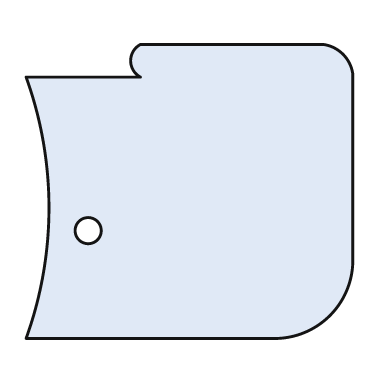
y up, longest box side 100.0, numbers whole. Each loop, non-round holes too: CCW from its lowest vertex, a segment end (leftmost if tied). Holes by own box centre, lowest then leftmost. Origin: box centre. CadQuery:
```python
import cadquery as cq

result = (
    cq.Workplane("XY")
    .moveTo(-50.0, -45.0)
    .lineTo(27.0, -45.0)
    .threePointArc((43.0, -38.0), (50.0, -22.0))
    .lineTo(50.0, 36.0)
    .threePointArc((47.0, 42.0), (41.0, 45.0))
    .lineTo(-15.0, 45.0)
    .threePointArc((-18.0, 40.0), (-15.0, 35.0))
    .lineTo(-50.0, 35.0)
    .threePointArc((-43.0, -5.0), (-50.0, -45.0))
    .close()
    .moveTo(-31.0, -12.0)
    .circle(4.0)
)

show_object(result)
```